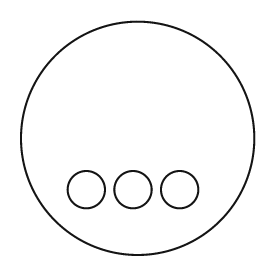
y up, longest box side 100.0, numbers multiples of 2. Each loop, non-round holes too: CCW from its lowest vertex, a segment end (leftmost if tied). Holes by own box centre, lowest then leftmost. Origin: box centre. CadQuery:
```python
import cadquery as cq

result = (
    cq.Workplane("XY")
    .moveTo(0.0, 0.0)
    .circle(50.0)
    .moveTo(-22.0, -22.0)
    .circle(8.0)
    .moveTo(-2.0, -22.0)
    .circle(8.0)
    .moveTo(18.0, -22.0)
    .circle(8.0)
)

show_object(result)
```